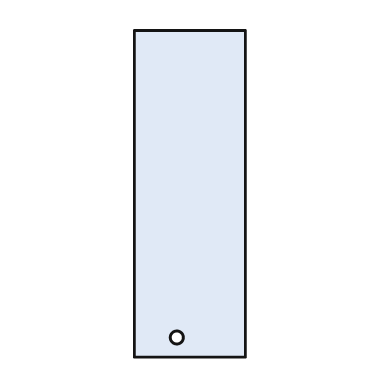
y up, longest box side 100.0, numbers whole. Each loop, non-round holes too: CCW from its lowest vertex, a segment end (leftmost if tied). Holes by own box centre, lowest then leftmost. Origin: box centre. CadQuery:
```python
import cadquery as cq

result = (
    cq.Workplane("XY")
    .moveTo(-17.0, -50.0)
    .lineTo(17.0, -50.0)
    .lineTo(17.0, 50.0)
    .lineTo(-17.0, 50.0)
    .close()
    .moveTo(-4.0, -44.0)
    .circle(2.0)
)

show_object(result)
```